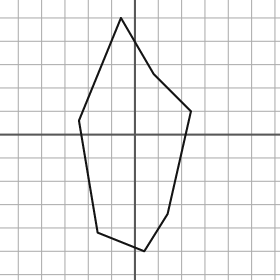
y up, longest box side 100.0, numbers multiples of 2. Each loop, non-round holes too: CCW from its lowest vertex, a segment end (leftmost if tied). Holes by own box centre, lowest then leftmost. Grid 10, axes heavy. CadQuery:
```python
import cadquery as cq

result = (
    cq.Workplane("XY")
    .moveTo(4.0, -50.0)
    .lineTo(14.0, -34.0)
    .lineTo(24.0, 10.0)
    .lineTo(8.0, 26.0)
    .lineTo(-6.0, 50.0)
    .lineTo(-24.0, 6.0)
    .lineTo(-16.0, -42.0)
    .close()
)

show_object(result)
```